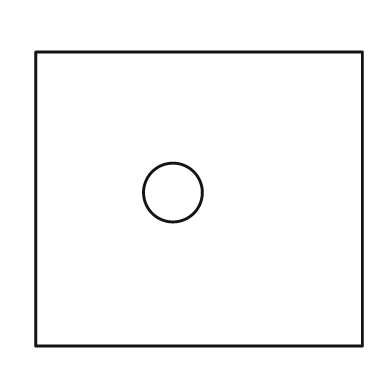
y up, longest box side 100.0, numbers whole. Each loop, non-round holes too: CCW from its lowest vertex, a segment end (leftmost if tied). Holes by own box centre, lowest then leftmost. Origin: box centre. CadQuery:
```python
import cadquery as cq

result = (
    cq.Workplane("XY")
    .moveTo(-50.0, -45.0)
    .lineTo(50.0, -45.0)
    .lineTo(50.0, 45.0)
    .lineTo(-50.0, 45.0)
    .close()
    .moveTo(-8.0, 2.0)
    .circle(9.0)
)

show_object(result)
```